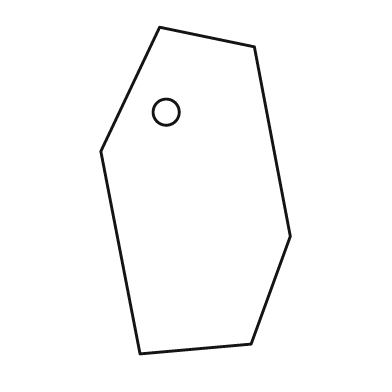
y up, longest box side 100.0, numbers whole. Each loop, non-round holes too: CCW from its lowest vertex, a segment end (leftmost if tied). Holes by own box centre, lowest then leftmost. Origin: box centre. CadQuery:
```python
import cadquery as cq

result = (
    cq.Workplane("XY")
    .moveTo(-17.0, -50.0)
    .lineTo(17.0, -47.0)
    .lineTo(29.0, -14.0)
    .lineTo(18.0, 44.0)
    .lineTo(-11.0, 50.0)
    .lineTo(-29.0, 12.0)
    .close()
    .moveTo(-9.0, 24.0)
    .circle(4.0)
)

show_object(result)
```